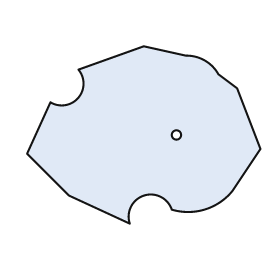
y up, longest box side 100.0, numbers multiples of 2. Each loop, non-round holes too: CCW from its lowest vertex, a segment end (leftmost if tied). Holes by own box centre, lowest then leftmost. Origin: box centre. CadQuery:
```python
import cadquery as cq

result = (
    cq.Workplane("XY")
    .moveTo(-6.0, -38.0)
    .threePointArc((0.0, -26.0), (12.0, -32.0))
    .threePointArc((26.0, -32.0), (38.0, -24.0))
    .lineTo(50.0, -6.0)
    .lineTo(40.0, 20.0)
    .lineTo(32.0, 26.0)
    .threePointArc((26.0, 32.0), (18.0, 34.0))
    .lineTo(0.0, 38.0)
    .lineTo(-28.0, 28.0)
    .threePointArc((-28.0, 16.0), (-40.0, 14.0))
    .lineTo(-50.0, -8.0)
    .lineTo(-32.0, -26.0)
    .close()
    .moveTo(14.0, 0.0)
    .circle(2.0)
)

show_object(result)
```